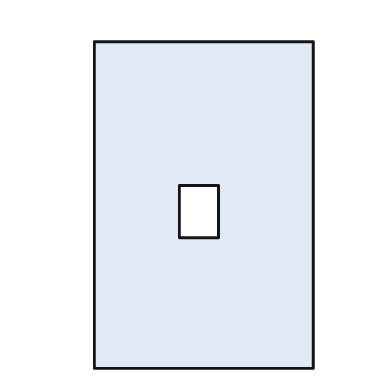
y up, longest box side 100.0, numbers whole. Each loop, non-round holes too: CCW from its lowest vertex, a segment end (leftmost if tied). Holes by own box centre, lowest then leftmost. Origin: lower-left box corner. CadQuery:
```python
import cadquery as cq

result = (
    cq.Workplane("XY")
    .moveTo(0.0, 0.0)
    .lineTo(67.0, 0.0)
    .lineTo(67.0, 100.0)
    .lineTo(0.0, 100.0)
    .close()
    .moveTo(26.0, 40.0)
    .lineTo(38.0, 40.0)
    .lineTo(38.0, 56.0)
    .lineTo(26.0, 56.0)
    .close()
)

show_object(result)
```